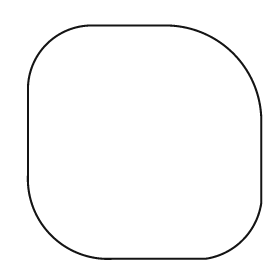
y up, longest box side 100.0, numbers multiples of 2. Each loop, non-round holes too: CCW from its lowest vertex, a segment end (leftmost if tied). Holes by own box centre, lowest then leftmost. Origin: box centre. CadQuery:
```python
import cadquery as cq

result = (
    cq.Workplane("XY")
    .moveTo(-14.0, -50.0)
    .lineTo(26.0, -50.0)
    .threePointArc((42.0, -42.0), (50.0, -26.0))
    .lineTo(50.0, 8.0)
    .threePointArc((38.0, 38.0), (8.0, 50.0))
    .lineTo(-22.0, 50.0)
    .threePointArc((-42.0, 42.0), (-50.0, 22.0))
    .lineTo(-50.0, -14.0)
    .threePointArc((-40.0, -40.0), (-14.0, -50.0))
    .close()
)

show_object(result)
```